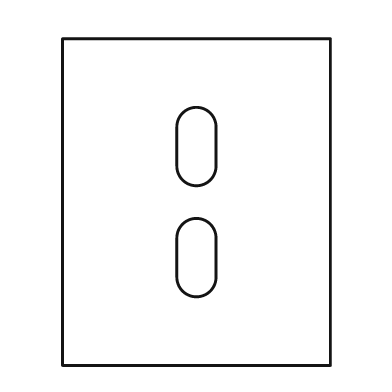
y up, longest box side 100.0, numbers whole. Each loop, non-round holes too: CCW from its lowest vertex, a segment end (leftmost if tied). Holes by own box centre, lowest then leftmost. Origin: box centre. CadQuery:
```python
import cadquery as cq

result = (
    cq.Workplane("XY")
    .moveTo(-41.0, -50.0)
    .lineTo(41.0, -50.0)
    .lineTo(41.0, 50.0)
    .lineTo(-41.0, 50.0)
    .close()
    .moveTo(-6.0, -23.0)
    .threePointArc((0.0, -29.0), (6.0, -23.0))
    .lineTo(6.0, -11.0)
    .threePointArc((0.0, -5.0), (-6.0, -11.0))
    .close()
    .moveTo(-6.0, 11.0)
    .threePointArc((0.0, 5.0), (6.0, 11.0))
    .lineTo(6.0, 23.0)
    .threePointArc((0.0, 29.0), (-6.0, 23.0))
    .close()
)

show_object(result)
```